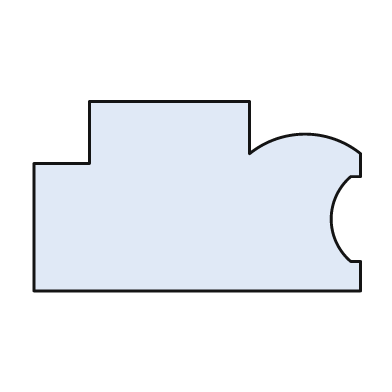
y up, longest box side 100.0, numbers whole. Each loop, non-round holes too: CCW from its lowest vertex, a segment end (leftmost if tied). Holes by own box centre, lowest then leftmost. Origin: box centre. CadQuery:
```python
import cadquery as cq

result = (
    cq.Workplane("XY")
    .moveTo(-50.0, -29.0)
    .lineTo(50.0, -29.0)
    .lineTo(50.0, -20.0)
    .lineTo(47.0, -20.0)
    .threePointArc((41.0, -7.0), (47.0, 6.0))
    .lineTo(50.0, 6.0)
    .lineTo(50.0, 13.0)
    .threePointArc((33.0, 19.0), (16.0, 13.0))
    .lineTo(16.0, 29.0)
    .lineTo(-33.0, 29.0)
    .lineTo(-33.0, 10.0)
    .lineTo(-50.0, 10.0)
    .close()
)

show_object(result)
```